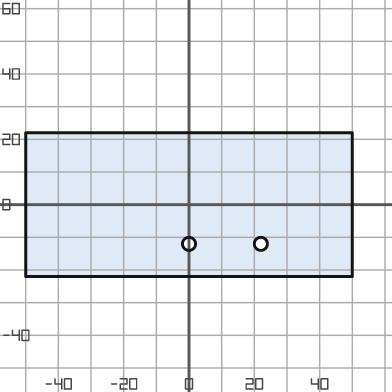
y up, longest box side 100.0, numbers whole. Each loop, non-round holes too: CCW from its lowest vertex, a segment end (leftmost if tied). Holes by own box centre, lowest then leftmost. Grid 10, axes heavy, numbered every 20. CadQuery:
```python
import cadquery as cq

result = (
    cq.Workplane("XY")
    .moveTo(-50.0, -22.0)
    .lineTo(50.0, -22.0)
    .lineTo(50.0, 22.0)
    .lineTo(-50.0, 22.0)
    .close()
    .moveTo(0.0, -12.0)
    .circle(2.0)
    .moveTo(22.0, -12.0)
    .circle(2.0)
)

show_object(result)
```